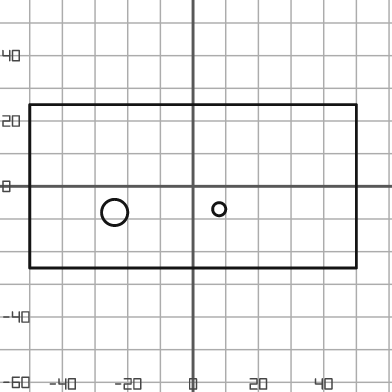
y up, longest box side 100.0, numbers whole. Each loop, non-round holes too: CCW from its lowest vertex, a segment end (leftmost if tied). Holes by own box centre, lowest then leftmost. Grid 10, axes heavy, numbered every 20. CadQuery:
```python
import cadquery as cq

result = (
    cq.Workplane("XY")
    .moveTo(-50.0, -25.0)
    .lineTo(50.0, -25.0)
    .lineTo(50.0, 25.0)
    .lineTo(-50.0, 25.0)
    .close()
    .moveTo(-24.0, -8.0)
    .circle(4.0)
    .moveTo(8.0, -7.0)
    .circle(2.0)
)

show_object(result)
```